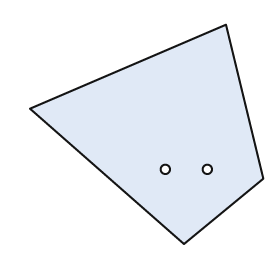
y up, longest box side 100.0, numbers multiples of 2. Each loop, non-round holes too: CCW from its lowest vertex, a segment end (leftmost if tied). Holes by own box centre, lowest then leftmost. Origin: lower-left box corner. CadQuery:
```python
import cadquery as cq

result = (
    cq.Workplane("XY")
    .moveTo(66.0, 0.0)
    .lineTo(100.0, 28.0)
    .lineTo(84.0, 94.0)
    .lineTo(0.0, 58.0)
    .close()
    .moveTo(58.0, 32.0)
    .circle(2.0)
    .moveTo(76.0, 32.0)
    .circle(2.0)
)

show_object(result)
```